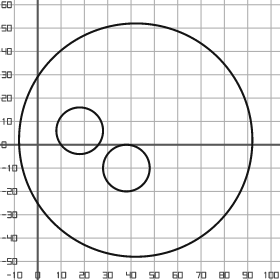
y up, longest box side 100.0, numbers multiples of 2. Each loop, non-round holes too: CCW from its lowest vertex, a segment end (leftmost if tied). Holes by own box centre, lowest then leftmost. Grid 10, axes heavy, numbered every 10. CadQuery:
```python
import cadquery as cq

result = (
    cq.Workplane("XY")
    .moveTo(42.0, 2.0)
    .circle(50.0)
    .moveTo(38.0, -10.0)
    .circle(10.0)
    .moveTo(18.0, 6.0)
    .circle(10.0)
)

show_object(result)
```